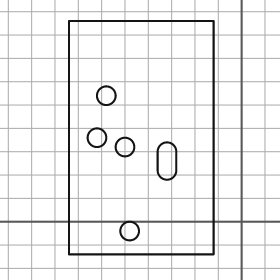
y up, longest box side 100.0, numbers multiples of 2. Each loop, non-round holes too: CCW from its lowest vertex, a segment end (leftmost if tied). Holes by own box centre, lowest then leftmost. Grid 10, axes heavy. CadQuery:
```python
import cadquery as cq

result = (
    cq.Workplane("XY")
    .moveTo(-74.0, -14.0)
    .lineTo(-12.0, -14.0)
    .lineTo(-12.0, 86.0)
    .lineTo(-74.0, 86.0)
    .close()
    .moveTo(-48.0, -4.0)
    .circle(4.0)
    .moveTo(-36.0, 22.0)
    .threePointArc((-32.0, 18.0), (-28.0, 22.0))
    .lineTo(-28.0, 30.0)
    .threePointArc((-32.0, 34.0), (-36.0, 30.0))
    .close()
    .moveTo(-50.0, 32.0)
    .circle(4.0)
    .moveTo(-62.0, 36.0)
    .circle(4.0)
    .moveTo(-58.0, 54.0)
    .circle(4.0)
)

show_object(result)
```